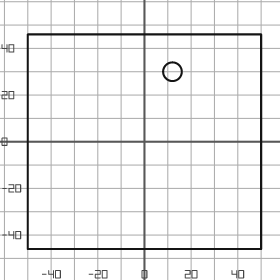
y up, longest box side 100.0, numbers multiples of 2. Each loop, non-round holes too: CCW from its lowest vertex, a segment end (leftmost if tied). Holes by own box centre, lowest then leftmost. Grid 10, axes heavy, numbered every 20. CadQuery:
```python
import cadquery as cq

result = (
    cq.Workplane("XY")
    .moveTo(-50.0, -46.0)
    .lineTo(50.0, -46.0)
    .lineTo(50.0, 46.0)
    .lineTo(-50.0, 46.0)
    .close()
    .moveTo(12.0, 30.0)
    .circle(4.0)
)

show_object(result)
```